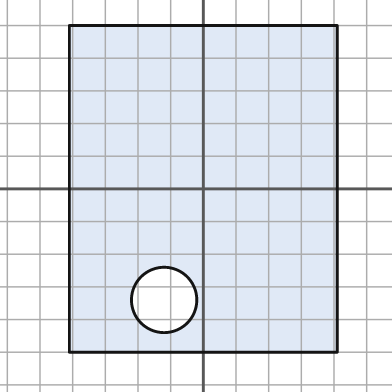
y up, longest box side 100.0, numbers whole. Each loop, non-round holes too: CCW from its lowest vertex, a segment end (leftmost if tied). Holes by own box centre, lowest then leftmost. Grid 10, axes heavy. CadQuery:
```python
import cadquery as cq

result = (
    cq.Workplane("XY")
    .moveTo(-41.0, -50.0)
    .lineTo(41.0, -50.0)
    .lineTo(41.0, 50.0)
    .lineTo(-41.0, 50.0)
    .close()
    .moveTo(-12.0, -34.0)
    .circle(10.0)
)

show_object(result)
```